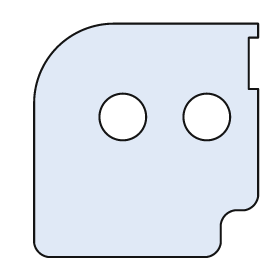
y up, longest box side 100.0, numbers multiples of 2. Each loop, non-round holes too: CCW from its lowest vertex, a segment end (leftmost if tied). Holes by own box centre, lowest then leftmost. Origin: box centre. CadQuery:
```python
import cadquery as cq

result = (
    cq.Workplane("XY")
    .moveTo(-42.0, -50.0)
    .lineTo(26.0, -50.0)
    .threePointArc((30.0, -48.0), (32.0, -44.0))
    .lineTo(32.0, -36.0)
    .threePointArc((34.0, -32.0), (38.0, -30.0))
    .lineTo(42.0, -30.0)
    .threePointArc((46.0, -28.0), (48.0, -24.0))
    .lineTo(48.0, 22.0)
    .lineTo(44.0, 22.0)
    .lineTo(44.0, 44.0)
    .lineTo(48.0, 44.0)
    .lineTo(48.0, 50.0)
    .lineTo(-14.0, 50.0)
    .threePointArc((-38.0, 40.0), (-48.0, 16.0))
    .lineTo(-48.0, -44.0)
    .threePointArc((-46.0, -48.0), (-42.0, -50.0))
    .close()
    .moveTo(-10.0, 10.0)
    .circle(10.0)
    .moveTo(26.0, 10.0)
    .circle(10.0)
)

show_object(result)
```